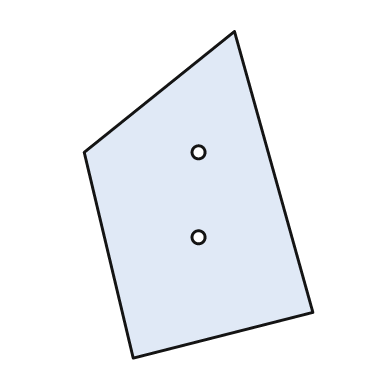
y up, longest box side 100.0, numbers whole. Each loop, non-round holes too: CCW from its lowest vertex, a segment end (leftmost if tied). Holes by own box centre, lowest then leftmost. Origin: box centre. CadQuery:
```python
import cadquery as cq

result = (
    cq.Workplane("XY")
    .moveTo(-20.0, -50.0)
    .lineTo(35.0, -36.0)
    .lineTo(11.0, 50.0)
    .lineTo(-35.0, 13.0)
    .close()
    .moveTo(0.0, -13.0)
    .circle(2.0)
    .moveTo(0.0, 13.0)
    .circle(2.0)
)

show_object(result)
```